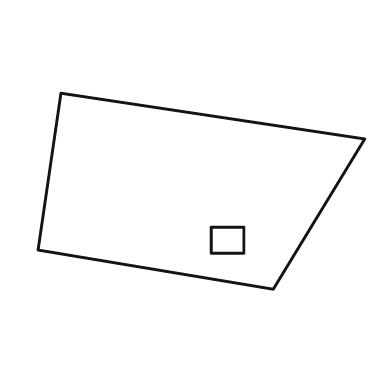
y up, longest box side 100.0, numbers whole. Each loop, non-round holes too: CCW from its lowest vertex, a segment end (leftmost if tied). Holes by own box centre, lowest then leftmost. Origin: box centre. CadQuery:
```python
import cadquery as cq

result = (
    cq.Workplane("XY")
    .moveTo(22.0, -30.0)
    .lineTo(50.0, 16.0)
    .lineTo(-43.0, 30.0)
    .lineTo(-50.0, -18.0)
    .close()
    .moveTo(3.0, -19.0)
    .lineTo(13.0, -19.0)
    .lineTo(13.0, -11.0)
    .lineTo(3.0, -11.0)
    .close()
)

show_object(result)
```